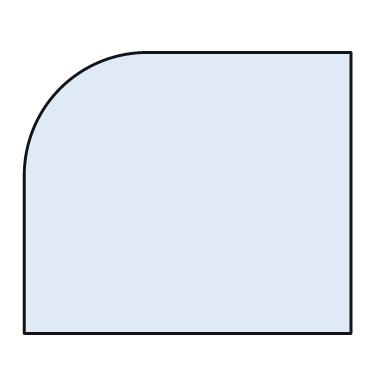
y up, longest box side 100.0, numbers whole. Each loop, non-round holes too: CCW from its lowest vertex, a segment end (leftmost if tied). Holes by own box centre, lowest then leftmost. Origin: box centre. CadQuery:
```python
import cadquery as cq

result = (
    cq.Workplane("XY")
    .moveTo(-50.0, -43.0)
    .lineTo(50.0, -43.0)
    .lineTo(50.0, 43.0)
    .lineTo(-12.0, 43.0)
    .threePointArc((-39.0, 32.0), (-50.0, 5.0))
    .close()
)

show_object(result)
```